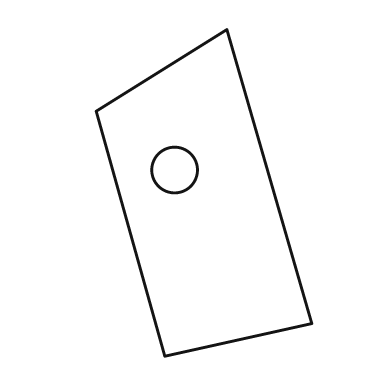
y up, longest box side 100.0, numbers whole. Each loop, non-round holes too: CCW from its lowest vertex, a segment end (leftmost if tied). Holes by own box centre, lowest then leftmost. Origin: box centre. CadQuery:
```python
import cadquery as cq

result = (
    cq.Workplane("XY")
    .moveTo(-12.0, -50.0)
    .lineTo(33.0, -40.0)
    .lineTo(7.0, 50.0)
    .lineTo(-33.0, 25.0)
    .close()
    .moveTo(-9.0, 7.0)
    .circle(7.0)
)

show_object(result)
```